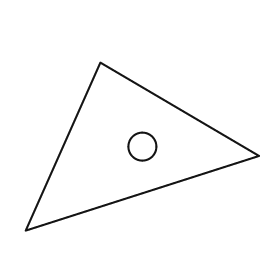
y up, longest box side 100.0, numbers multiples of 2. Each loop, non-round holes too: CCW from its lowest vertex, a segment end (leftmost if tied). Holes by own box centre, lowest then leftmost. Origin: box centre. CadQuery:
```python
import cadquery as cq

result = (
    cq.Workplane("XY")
    .moveTo(-50.0, -36.0)
    .lineTo(50.0, -4.0)
    .lineTo(-18.0, 36.0)
    .close()
    .moveTo(0.0, 0.0)
    .circle(6.0)
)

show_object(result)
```